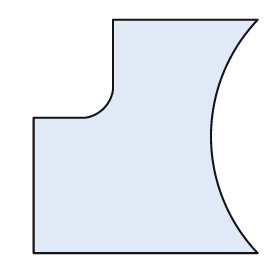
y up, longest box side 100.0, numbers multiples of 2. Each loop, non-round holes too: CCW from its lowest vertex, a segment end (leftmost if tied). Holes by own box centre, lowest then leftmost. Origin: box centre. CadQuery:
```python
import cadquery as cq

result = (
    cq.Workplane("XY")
    .moveTo(-48.0, -50.0)
    .lineTo(48.0, -50.0)
    .threePointArc((28.0, 0.0), (48.0, 50.0))
    .lineTo(-14.0, 50.0)
    .lineTo(-14.0, 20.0)
    .threePointArc((-18.0, 12.0), (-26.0, 8.0))
    .lineTo(-48.0, 8.0)
    .close()
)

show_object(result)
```